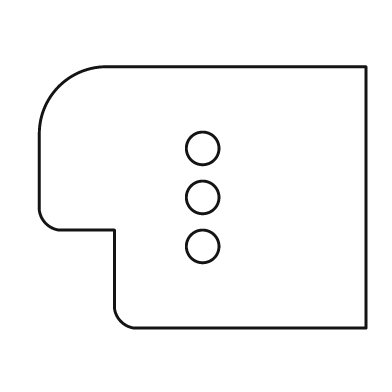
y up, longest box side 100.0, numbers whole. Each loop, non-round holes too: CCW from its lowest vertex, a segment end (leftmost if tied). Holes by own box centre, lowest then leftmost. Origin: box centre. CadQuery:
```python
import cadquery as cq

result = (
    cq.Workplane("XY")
    .moveTo(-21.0, -40.0)
    .lineTo(50.0, -40.0)
    .lineTo(50.0, 40.0)
    .lineTo(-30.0, 40.0)
    .threePointArc((-44.0, 34.0), (-50.0, 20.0))
    .lineTo(-50.0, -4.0)
    .threePointArc((-48.0, -8.0), (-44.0, -10.0))
    .lineTo(-27.0, -10.0)
    .lineTo(-27.0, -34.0)
    .threePointArc((-25.0, -38.0), (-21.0, -40.0))
    .close()
    .moveTo(0.0, -15.0)
    .circle(5.0)
    .moveTo(0.0, 0.0)
    .circle(5.0)
    .moveTo(0.0, 15.0)
    .circle(5.0)
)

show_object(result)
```